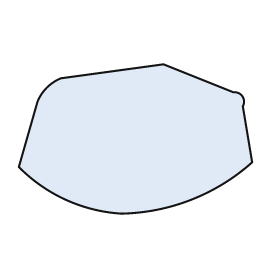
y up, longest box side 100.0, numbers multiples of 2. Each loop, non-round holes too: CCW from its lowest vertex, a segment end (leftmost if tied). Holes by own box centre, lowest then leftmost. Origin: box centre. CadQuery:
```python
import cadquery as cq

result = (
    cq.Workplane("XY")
    .moveTo(-6.0, -32.0)
    .threePointArc((24.0, -26.0), (50.0, -10.0))
    .lineTo(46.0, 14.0)
    .threePointArc((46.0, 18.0), (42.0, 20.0))
    .lineTo(12.0, 32.0)
    .lineTo(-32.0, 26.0)
    .threePointArc((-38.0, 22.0), (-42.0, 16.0))
    .lineTo(-50.0, -12.0)
    .threePointArc((-30.0, -26.0), (-6.0, -32.0))
    .close()
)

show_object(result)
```